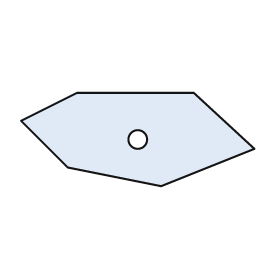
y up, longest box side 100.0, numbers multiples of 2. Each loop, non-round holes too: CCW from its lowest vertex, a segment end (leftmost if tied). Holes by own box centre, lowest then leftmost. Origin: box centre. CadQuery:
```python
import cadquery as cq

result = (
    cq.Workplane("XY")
    .moveTo(10.0, -20.0)
    .lineTo(50.0, -4.0)
    .lineTo(24.0, 20.0)
    .lineTo(-26.0, 20.0)
    .lineTo(-50.0, 8.0)
    .lineTo(-30.0, -12.0)
    .close()
    .moveTo(0.0, 0.0)
    .circle(4.0)
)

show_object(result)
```